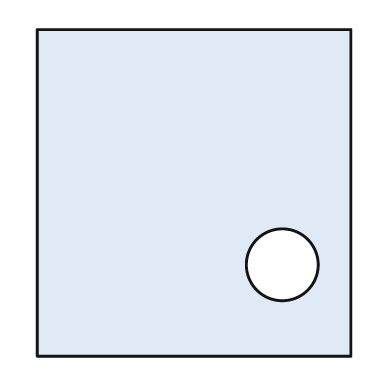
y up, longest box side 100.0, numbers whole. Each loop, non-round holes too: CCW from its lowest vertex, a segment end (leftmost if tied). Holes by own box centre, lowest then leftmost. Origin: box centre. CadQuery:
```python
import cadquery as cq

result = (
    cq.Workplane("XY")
    .moveTo(-48.0, -50.0)
    .lineTo(48.0, -50.0)
    .lineTo(48.0, 50.0)
    .lineTo(-48.0, 50.0)
    .close()
    .moveTo(27.0, -22.0)
    .circle(11.0)
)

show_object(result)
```